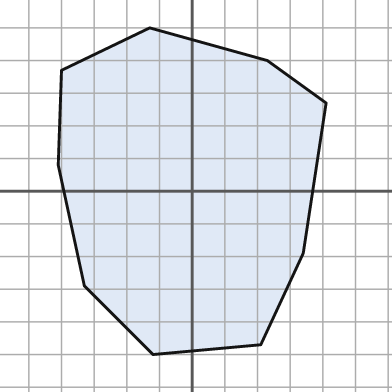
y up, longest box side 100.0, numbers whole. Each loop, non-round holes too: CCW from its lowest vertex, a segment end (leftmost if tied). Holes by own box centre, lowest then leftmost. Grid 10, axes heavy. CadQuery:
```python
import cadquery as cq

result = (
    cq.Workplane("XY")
    .moveTo(-12.0, -50.0)
    .lineTo(21.0, -47.0)
    .lineTo(34.0, -19.0)
    .lineTo(41.0, 27.0)
    .lineTo(23.0, 40.0)
    .lineTo(-13.0, 50.0)
    .lineTo(-40.0, 37.0)
    .lineTo(-41.0, 8.0)
    .lineTo(-33.0, -29.0)
    .close()
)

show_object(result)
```